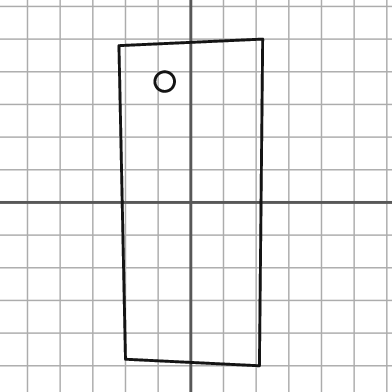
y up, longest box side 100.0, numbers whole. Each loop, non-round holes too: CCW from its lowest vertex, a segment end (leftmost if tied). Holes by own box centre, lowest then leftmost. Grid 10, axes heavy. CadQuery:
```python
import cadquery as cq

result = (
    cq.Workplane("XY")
    .moveTo(21.0, -50.0)
    .lineTo(22.0, 50.0)
    .lineTo(-22.0, 48.0)
    .lineTo(-20.0, -48.0)
    .close()
    .moveTo(-8.0, 37.0)
    .circle(3.0)
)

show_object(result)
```